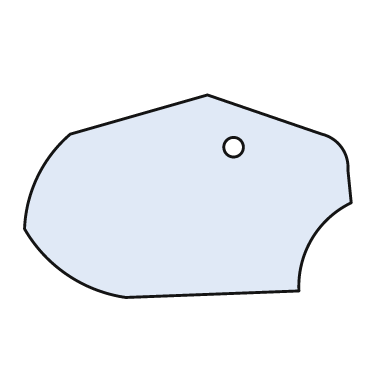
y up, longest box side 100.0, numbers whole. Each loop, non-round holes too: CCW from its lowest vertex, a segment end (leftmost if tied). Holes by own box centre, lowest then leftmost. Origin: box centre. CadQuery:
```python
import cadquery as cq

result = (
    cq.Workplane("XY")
    .moveTo(-19.0, -31.0)
    .lineTo(34.0, -29.0)
    .threePointArc((38.0, -13.0), (50.0, -2.0))
    .lineTo(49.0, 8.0)
    .threePointArc((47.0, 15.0), (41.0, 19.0))
    .lineTo(6.0, 31.0)
    .lineTo(-36.0, 19.0)
    .threePointArc((-46.0, 6.0), (-50.0, -10.0))
    .threePointArc((-37.0, -24.0), (-19.0, -31.0))
    .close()
    .moveTo(14.0, 15.0)
    .circle(3.0)
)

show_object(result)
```